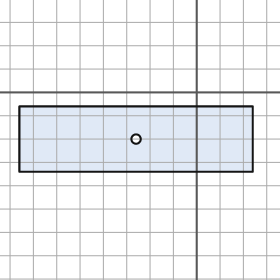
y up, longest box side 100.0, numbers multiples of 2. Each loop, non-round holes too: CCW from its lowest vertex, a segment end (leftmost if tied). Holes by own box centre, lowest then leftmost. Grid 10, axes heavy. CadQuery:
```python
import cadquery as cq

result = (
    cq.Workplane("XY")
    .moveTo(-76.0, -34.0)
    .lineTo(24.0, -34.0)
    .lineTo(24.0, -6.0)
    .lineTo(-76.0, -6.0)
    .close()
    .moveTo(-26.0, -20.0)
    .circle(2.0)
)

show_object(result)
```